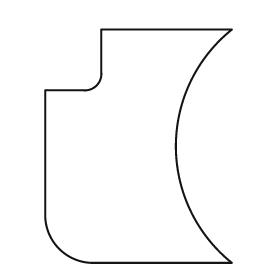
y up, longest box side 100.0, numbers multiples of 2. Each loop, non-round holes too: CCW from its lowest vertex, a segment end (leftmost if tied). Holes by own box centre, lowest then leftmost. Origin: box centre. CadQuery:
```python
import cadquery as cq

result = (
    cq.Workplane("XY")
    .moveTo(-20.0, -50.0)
    .lineTo(40.0, -50.0)
    .threePointArc((16.0, 0.0), (40.0, 50.0))
    .lineTo(-16.0, 50.0)
    .lineTo(-16.0, 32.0)
    .threePointArc((-18.0, 26.0), (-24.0, 24.0))
    .lineTo(-40.0, 24.0)
    .lineTo(-40.0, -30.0)
    .threePointArc((-34.0, -44.0), (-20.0, -50.0))
    .close()
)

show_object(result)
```